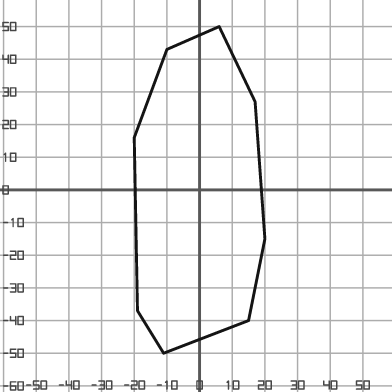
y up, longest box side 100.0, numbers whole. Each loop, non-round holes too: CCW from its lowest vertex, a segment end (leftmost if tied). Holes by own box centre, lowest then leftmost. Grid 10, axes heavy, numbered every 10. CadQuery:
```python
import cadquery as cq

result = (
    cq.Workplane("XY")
    .moveTo(-11.0, -50.0)
    .lineTo(15.0, -40.0)
    .lineTo(20.0, -15.0)
    .lineTo(17.0, 27.0)
    .lineTo(6.0, 50.0)
    .lineTo(-10.0, 43.0)
    .lineTo(-20.0, 16.0)
    .lineTo(-19.0, -37.0)
    .close()
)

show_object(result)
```